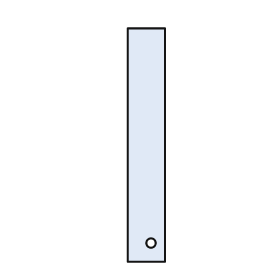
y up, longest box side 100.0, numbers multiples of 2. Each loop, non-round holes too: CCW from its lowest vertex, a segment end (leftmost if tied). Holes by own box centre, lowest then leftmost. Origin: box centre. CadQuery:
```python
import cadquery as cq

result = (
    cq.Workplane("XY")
    .moveTo(-8.0, -50.0)
    .lineTo(8.0, -50.0)
    .lineTo(8.0, 50.0)
    .lineTo(-8.0, 50.0)
    .close()
    .moveTo(2.0, -42.0)
    .circle(2.0)
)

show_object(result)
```